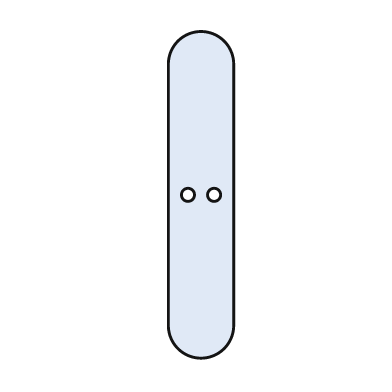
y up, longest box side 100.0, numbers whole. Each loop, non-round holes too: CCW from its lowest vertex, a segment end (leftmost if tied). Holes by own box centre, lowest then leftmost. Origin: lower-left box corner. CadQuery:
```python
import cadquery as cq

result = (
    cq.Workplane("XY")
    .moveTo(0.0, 10.0)
    .threePointArc((10.0, 0.0), (20.0, 10.0))
    .lineTo(20.0, 90.0)
    .threePointArc((10.0, 100.0), (0.0, 90.0))
    .close()
    .moveTo(6.0, 50.0)
    .circle(2.0)
    .moveTo(14.0, 50.0)
    .circle(2.0)
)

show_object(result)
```